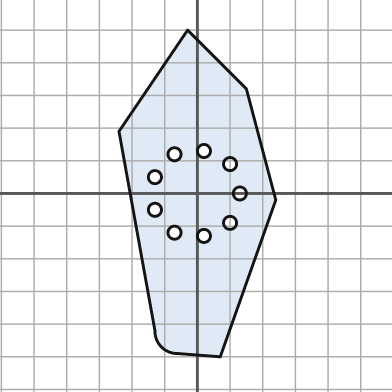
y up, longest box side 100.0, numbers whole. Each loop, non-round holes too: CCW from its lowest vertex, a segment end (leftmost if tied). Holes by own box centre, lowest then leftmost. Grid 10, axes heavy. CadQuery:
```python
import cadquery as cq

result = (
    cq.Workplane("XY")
    .moveTo(7.0, -50.0)
    .lineTo(24.0, -2.0)
    .lineTo(15.0, 32.0)
    .lineTo(-3.0, 50.0)
    .lineTo(-24.0, 19.0)
    .lineTo(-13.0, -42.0)
    .threePointArc((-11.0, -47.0), (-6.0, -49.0))
    .close()
    .moveTo(2.0, -13.0)
    .circle(2.0)
    .moveTo(-7.0, -12.0)
    .circle(2.0)
    .moveTo(10.0, -9.0)
    .circle(2.0)
    .moveTo(-13.0, -5.0)
    .circle(2.0)
    .moveTo(13.0, 0.0)
    .circle(2.0)
    .moveTo(-13.0, 5.0)
    .circle(2.0)
    .moveTo(10.0, 9.0)
    .circle(2.0)
    .moveTo(-7.0, 12.0)
    .circle(2.0)
    .moveTo(2.0, 13.0)
    .circle(2.0)
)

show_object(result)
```